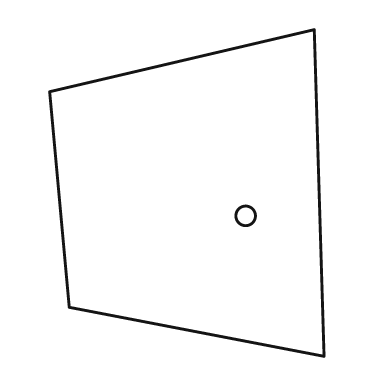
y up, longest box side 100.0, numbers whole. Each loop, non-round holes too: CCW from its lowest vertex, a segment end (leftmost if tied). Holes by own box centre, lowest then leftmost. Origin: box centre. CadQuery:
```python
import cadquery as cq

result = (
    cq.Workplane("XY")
    .moveTo(42.0, -50.0)
    .lineTo(39.0, 50.0)
    .lineTo(-42.0, 31.0)
    .lineTo(-36.0, -35.0)
    .close()
    .moveTo(18.0, -7.0)
    .circle(3.0)
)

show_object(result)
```